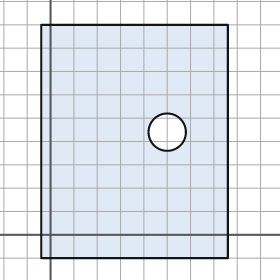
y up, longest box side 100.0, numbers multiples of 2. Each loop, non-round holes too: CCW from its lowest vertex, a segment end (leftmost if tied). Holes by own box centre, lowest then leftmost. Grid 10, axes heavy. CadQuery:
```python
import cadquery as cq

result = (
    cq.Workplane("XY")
    .moveTo(-4.0, -10.0)
    .lineTo(76.0, -10.0)
    .lineTo(76.0, 90.0)
    .lineTo(-4.0, 90.0)
    .close()
    .moveTo(50.0, 44.0)
    .circle(8.0)
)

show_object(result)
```